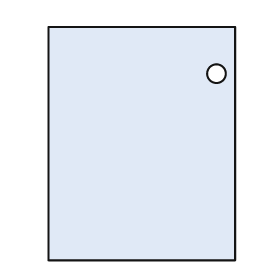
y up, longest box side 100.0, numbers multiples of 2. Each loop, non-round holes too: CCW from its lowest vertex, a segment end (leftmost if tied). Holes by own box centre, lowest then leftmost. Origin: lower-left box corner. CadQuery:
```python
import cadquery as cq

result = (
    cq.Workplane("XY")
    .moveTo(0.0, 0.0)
    .lineTo(80.0, 0.0)
    .lineTo(80.0, 100.0)
    .lineTo(0.0, 100.0)
    .close()
    .moveTo(72.0, 80.0)
    .circle(4.0)
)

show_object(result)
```